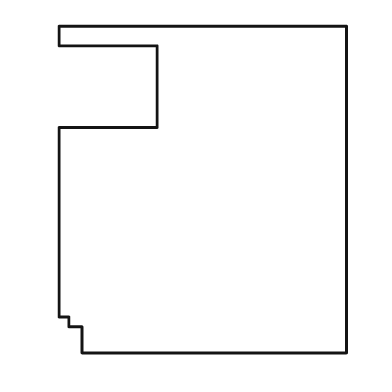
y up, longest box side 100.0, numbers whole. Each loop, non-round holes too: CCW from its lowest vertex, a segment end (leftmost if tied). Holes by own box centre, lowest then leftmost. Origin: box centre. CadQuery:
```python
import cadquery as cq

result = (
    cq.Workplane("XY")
    .moveTo(-37.0, -50.0)
    .lineTo(44.0, -50.0)
    .lineTo(44.0, 50.0)
    .lineTo(-44.0, 50.0)
    .lineTo(-44.0, 44.0)
    .lineTo(-14.0, 44.0)
    .lineTo(-14.0, 19.0)
    .lineTo(-44.0, 19.0)
    .lineTo(-44.0, -39.0)
    .lineTo(-41.0, -39.0)
    .lineTo(-41.0, -42.0)
    .lineTo(-37.0, -42.0)
    .close()
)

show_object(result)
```